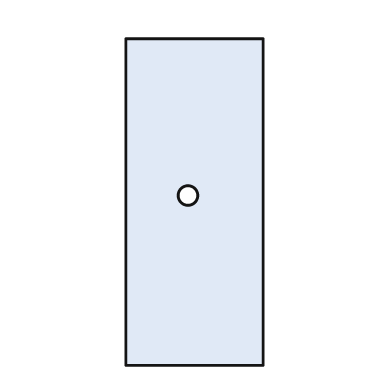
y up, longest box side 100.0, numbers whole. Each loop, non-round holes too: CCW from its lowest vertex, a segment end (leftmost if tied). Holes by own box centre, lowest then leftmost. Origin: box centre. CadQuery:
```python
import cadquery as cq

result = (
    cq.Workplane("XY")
    .moveTo(-21.0, -50.0)
    .lineTo(21.0, -50.0)
    .lineTo(21.0, 50.0)
    .lineTo(-21.0, 50.0)
    .close()
    .moveTo(-2.0, 2.0)
    .circle(3.0)
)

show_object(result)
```